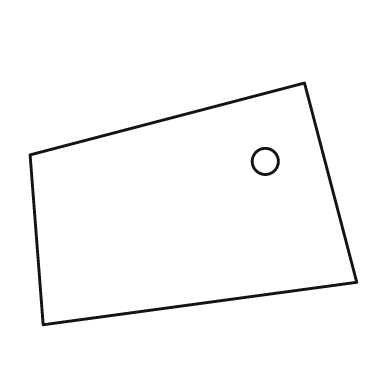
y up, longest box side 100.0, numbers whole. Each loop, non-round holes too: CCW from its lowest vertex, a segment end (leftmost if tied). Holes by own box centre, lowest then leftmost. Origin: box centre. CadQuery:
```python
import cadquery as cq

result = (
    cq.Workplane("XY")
    .moveTo(-46.0, -37.0)
    .lineTo(50.0, -24.0)
    .lineTo(34.0, 37.0)
    .lineTo(-50.0, 15.0)
    .close()
    .moveTo(22.0, 13.0)
    .circle(4.0)
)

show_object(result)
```